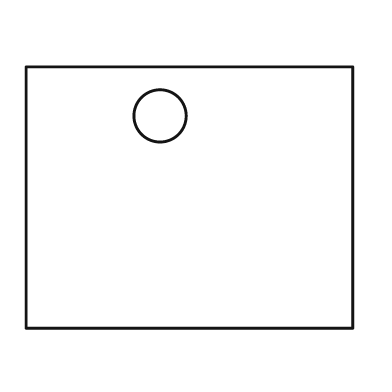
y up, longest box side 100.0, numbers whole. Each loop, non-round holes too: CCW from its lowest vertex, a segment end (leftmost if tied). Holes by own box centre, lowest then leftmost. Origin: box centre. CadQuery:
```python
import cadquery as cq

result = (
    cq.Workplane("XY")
    .moveTo(-50.0, -40.0)
    .lineTo(50.0, -40.0)
    .lineTo(50.0, 40.0)
    .lineTo(-50.0, 40.0)
    .close()
    .moveTo(-9.0, 25.0)
    .circle(8.0)
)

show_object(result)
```